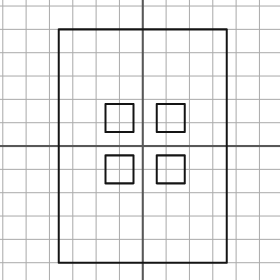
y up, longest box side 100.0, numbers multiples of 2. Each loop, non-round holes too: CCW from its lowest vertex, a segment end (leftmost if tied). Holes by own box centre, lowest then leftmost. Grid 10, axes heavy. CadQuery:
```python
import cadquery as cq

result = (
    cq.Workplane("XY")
    .moveTo(-36.0, -50.0)
    .lineTo(36.0, -50.0)
    .lineTo(36.0, 50.0)
    .lineTo(-36.0, 50.0)
    .close()
    .moveTo(-16.0, -16.0)
    .lineTo(-4.0, -16.0)
    .lineTo(-4.0, -4.0)
    .lineTo(-16.0, -4.0)
    .close()
    .moveTo(6.0, -16.0)
    .lineTo(18.0, -16.0)
    .lineTo(18.0, -4.0)
    .lineTo(6.0, -4.0)
    .close()
    .moveTo(-16.0, 6.0)
    .lineTo(-4.0, 6.0)
    .lineTo(-4.0, 18.0)
    .lineTo(-16.0, 18.0)
    .close()
    .moveTo(6.0, 6.0)
    .lineTo(18.0, 6.0)
    .lineTo(18.0, 18.0)
    .lineTo(6.0, 18.0)
    .close()
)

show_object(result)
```